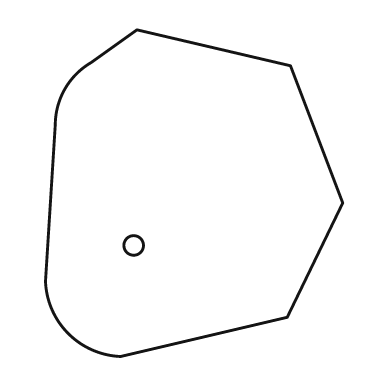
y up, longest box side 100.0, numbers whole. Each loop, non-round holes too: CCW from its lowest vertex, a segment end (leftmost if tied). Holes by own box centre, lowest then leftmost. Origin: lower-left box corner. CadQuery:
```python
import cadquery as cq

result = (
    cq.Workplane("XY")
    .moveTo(23.0, 0.0)
    .lineTo(74.0, 12.0)
    .lineTo(91.0, 47.0)
    .lineTo(75.0, 89.0)
    .lineTo(28.0, 100.0)
    .lineTo(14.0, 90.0)
    .threePointArc((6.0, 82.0), (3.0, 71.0))
    .lineTo(0.0, 23.0)
    .threePointArc((7.0, 7.0), (23.0, 0.0))
    .close()
    .moveTo(27.0, 34.0)
    .circle(3.0)
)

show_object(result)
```